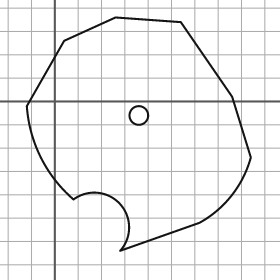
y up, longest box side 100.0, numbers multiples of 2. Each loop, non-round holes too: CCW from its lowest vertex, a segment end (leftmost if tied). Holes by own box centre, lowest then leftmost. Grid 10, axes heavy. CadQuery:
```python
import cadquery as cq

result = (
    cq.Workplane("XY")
    .moveTo(28.0, -64.0)
    .lineTo(62.0, -52.0)
    .threePointArc((76.0, -40.0), (84.0, -24.0))
    .lineTo(76.0, 2.0)
    .lineTo(54.0, 34.0)
    .lineTo(26.0, 36.0)
    .lineTo(4.0, 26.0)
    .lineTo(-12.0, -2.0)
    .threePointArc((-6.0, -24.0), (8.0, -42.0))
    .threePointArc((28.0, -44.0), (28.0, -64.0))
    .close()
    .moveTo(36.0, -6.0)
    .circle(4.0)
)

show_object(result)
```